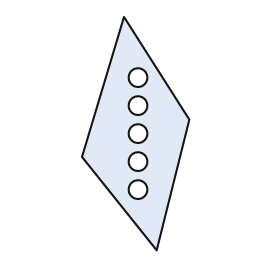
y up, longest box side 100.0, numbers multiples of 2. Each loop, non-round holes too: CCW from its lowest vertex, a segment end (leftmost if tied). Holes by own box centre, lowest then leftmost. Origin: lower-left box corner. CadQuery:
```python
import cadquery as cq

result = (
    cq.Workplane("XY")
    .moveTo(32.0, 0.0)
    .lineTo(46.0, 56.0)
    .lineTo(18.0, 100.0)
    .lineTo(0.0, 40.0)
    .close()
    .moveTo(24.0, 26.0)
    .circle(4.0)
    .moveTo(24.0, 38.0)
    .circle(4.0)
    .moveTo(24.0, 50.0)
    .circle(4.0)
    .moveTo(24.0, 62.0)
    .circle(4.0)
    .moveTo(24.0, 74.0)
    .circle(4.0)
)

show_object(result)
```